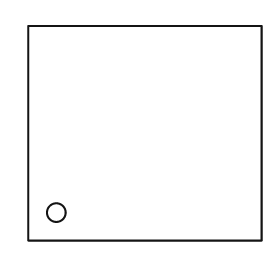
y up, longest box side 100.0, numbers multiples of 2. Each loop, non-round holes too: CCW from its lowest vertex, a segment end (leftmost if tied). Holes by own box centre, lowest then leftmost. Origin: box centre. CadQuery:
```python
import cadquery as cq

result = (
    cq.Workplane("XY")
    .moveTo(-50.0, -46.0)
    .lineTo(50.0, -46.0)
    .lineTo(50.0, 46.0)
    .lineTo(-50.0, 46.0)
    .close()
    .moveTo(-38.0, -34.0)
    .circle(4.0)
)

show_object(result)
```